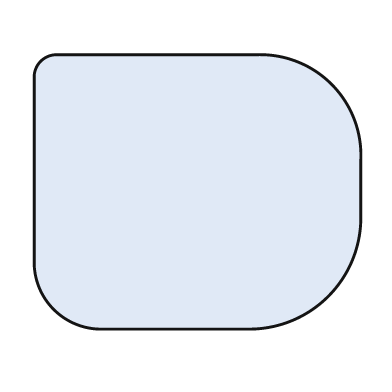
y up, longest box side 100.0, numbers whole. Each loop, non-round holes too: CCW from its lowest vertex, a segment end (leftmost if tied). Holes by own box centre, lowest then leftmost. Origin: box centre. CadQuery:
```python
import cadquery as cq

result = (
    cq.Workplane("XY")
    .moveTo(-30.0, -42.0)
    .lineTo(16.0, -42.0)
    .threePointArc((40.0, -32.0), (50.0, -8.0))
    .lineTo(50.0, 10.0)
    .threePointArc((41.0, 33.0), (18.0, 42.0))
    .lineTo(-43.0, 42.0)
    .threePointArc((-48.0, 40.0), (-50.0, 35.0))
    .lineTo(-50.0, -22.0)
    .threePointArc((-44.0, -36.0), (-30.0, -42.0))
    .close()
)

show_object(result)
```